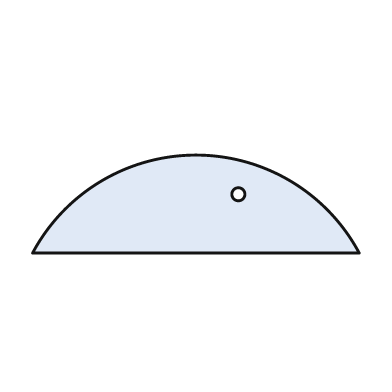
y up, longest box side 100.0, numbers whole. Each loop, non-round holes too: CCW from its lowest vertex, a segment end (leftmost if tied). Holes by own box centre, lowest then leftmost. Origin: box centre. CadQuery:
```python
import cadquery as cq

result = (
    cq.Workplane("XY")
    .moveTo(-50.0, -15.0)
    .lineTo(50.0, -15.0)
    .threePointArc((0.0, 15.0), (-50.0, -15.0))
    .close()
    .moveTo(13.0, 3.0)
    .circle(2.0)
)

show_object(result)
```